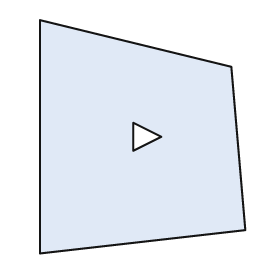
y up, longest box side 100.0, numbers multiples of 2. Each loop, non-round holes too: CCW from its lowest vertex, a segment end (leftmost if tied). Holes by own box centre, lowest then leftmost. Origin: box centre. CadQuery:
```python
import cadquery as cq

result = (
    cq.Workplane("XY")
    .moveTo(-44.0, -50.0)
    .lineTo(44.0, -40.0)
    .lineTo(38.0, 30.0)
    .lineTo(-44.0, 50.0)
    .close()
    .moveTo(-4.0, -6.0)
    .lineTo(8.0, 0.0)
    .lineTo(-4.0, 6.0)
    .close()
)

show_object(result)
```